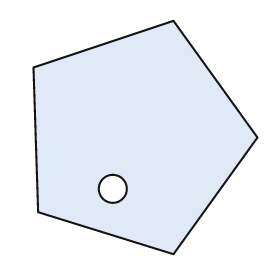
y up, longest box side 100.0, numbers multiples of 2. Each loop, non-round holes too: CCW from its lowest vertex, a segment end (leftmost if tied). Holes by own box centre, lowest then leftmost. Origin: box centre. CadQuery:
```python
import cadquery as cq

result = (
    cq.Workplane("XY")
    .moveTo(12.0, -50.0)
    .lineTo(48.0, 0.0)
    .lineTo(12.0, 50.0)
    .lineTo(-48.0, 30.0)
    .lineTo(-46.0, -32.0)
    .close()
    .moveTo(-14.0, -22.0)
    .circle(6.0)
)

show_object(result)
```